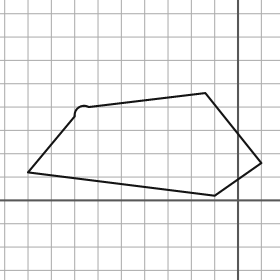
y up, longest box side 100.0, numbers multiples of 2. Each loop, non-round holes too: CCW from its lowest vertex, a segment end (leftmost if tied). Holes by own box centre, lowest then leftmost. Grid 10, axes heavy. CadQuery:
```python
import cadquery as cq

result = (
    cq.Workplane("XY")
    .moveTo(-10.0, 2.0)
    .lineTo(10.0, 16.0)
    .lineTo(-14.0, 46.0)
    .lineTo(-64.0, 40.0)
    .threePointArc((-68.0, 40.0), (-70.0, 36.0))
    .lineTo(-90.0, 12.0)
    .close()
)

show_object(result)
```